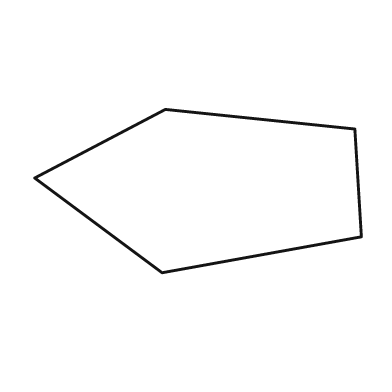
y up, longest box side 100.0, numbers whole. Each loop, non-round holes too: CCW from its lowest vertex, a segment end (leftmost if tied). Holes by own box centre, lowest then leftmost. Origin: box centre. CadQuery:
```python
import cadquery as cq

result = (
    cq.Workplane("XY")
    .moveTo(-11.0, -25.0)
    .lineTo(50.0, -14.0)
    .lineTo(48.0, 19.0)
    .lineTo(-10.0, 25.0)
    .lineTo(-50.0, 4.0)
    .close()
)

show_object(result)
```